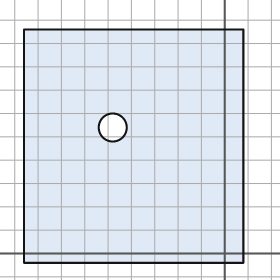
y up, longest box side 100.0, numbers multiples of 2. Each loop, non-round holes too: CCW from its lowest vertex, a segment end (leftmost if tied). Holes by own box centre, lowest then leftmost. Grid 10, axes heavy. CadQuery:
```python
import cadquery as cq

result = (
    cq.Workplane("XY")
    .moveTo(-86.0, -4.0)
    .lineTo(8.0, -4.0)
    .lineTo(8.0, 96.0)
    .lineTo(-86.0, 96.0)
    .close()
    .moveTo(-48.0, 54.0)
    .circle(6.0)
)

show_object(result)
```